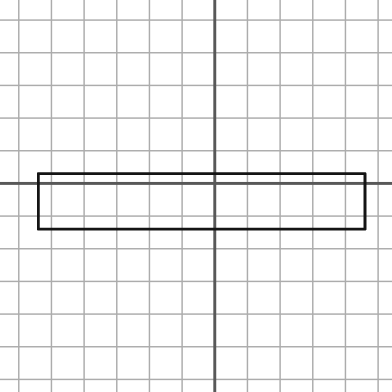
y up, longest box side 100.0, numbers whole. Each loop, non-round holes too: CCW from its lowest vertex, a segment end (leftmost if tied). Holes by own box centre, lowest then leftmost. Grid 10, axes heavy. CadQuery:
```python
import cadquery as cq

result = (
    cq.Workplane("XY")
    .moveTo(-54.0, -14.0)
    .lineTo(46.0, -14.0)
    .lineTo(46.0, 3.0)
    .lineTo(-54.0, 3.0)
    .close()
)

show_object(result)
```